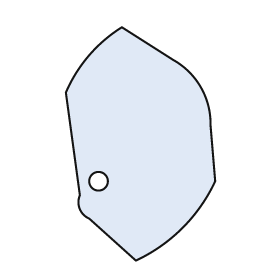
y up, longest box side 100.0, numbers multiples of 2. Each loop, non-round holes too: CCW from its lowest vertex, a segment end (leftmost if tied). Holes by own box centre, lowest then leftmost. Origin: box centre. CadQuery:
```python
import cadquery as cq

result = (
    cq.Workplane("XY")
    .moveTo(-2.0, -50.0)
    .threePointArc((18.0, -36.0), (32.0, -16.0))
    .lineTo(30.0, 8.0)
    .threePointArc((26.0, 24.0), (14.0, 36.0))
    .lineTo(-8.0, 50.0)
    .threePointArc((-22.0, 38.0), (-32.0, 22.0))
    .lineTo(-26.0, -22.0)
    .threePointArc((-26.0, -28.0), (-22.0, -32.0))
    .close()
    .moveTo(-18.0, -16.0)
    .circle(4.0)
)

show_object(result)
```